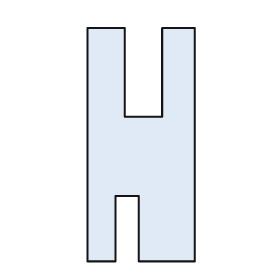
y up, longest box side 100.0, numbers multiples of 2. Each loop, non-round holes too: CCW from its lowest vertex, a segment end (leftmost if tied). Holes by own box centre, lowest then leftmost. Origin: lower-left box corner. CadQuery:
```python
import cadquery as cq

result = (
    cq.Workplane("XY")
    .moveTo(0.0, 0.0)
    .lineTo(12.0, 0.0)
    .lineTo(12.0, 28.0)
    .lineTo(22.0, 28.0)
    .lineTo(22.0, 0.0)
    .lineTo(46.0, 0.0)
    .lineTo(46.0, 100.0)
    .lineTo(32.0, 100.0)
    .lineTo(32.0, 62.0)
    .lineTo(16.0, 62.0)
    .lineTo(16.0, 100.0)
    .lineTo(0.0, 100.0)
    .close()
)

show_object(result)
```